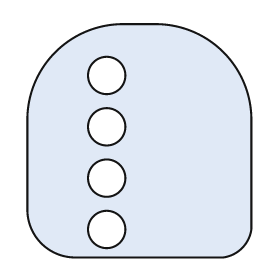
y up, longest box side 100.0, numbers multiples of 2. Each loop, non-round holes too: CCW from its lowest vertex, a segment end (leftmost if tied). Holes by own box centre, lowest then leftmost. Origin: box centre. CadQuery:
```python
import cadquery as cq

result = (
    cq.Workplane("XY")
    .moveTo(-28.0, -50.0)
    .lineTo(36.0, -50.0)
    .threePointArc((44.0, -46.0), (48.0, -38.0))
    .lineTo(48.0, 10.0)
    .threePointArc((36.0, 38.0), (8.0, 50.0))
    .lineTo(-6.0, 50.0)
    .threePointArc((-36.0, 38.0), (-48.0, 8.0))
    .lineTo(-48.0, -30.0)
    .threePointArc((-42.0, -44.0), (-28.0, -50.0))
    .close()
    .moveTo(-14.0, -38.0)
    .circle(8.0)
    .moveTo(-14.0, -16.0)
    .circle(8.0)
    .moveTo(-14.0, 6.0)
    .circle(8.0)
    .moveTo(-14.0, 28.0)
    .circle(8.0)
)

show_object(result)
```